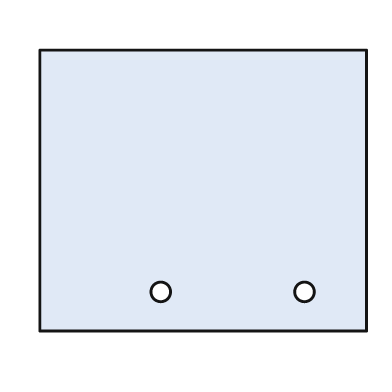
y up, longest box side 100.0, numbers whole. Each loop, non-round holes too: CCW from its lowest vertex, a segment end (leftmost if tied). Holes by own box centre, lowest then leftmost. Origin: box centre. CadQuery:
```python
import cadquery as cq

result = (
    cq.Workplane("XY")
    .moveTo(-50.0, -43.0)
    .lineTo(50.0, -43.0)
    .lineTo(50.0, 43.0)
    .lineTo(-50.0, 43.0)
    .close()
    .moveTo(-13.0, -31.0)
    .circle(3.0)
    .moveTo(31.0, -31.0)
    .circle(3.0)
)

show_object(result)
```